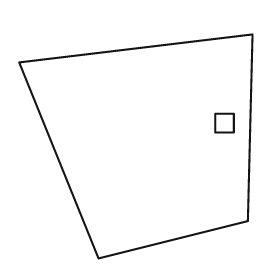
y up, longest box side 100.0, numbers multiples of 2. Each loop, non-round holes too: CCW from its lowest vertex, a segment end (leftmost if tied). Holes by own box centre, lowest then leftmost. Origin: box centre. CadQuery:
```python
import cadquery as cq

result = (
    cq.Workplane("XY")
    .moveTo(-16.0, -48.0)
    .lineTo(48.0, -32.0)
    .lineTo(50.0, 48.0)
    .lineTo(-50.0, 36.0)
    .close()
    .moveTo(34.0, 6.0)
    .lineTo(42.0, 6.0)
    .lineTo(42.0, 14.0)
    .lineTo(34.0, 14.0)
    .close()
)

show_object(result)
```